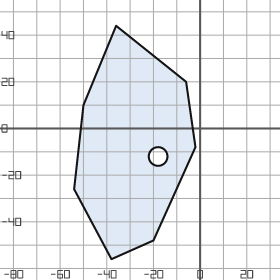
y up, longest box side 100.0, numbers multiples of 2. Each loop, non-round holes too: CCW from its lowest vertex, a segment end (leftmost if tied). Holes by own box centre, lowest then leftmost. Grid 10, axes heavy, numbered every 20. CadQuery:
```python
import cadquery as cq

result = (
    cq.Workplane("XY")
    .moveTo(-38.0, -56.0)
    .lineTo(-20.0, -48.0)
    .lineTo(-2.0, -8.0)
    .lineTo(-6.0, 20.0)
    .lineTo(-36.0, 44.0)
    .lineTo(-50.0, 10.0)
    .lineTo(-54.0, -26.0)
    .close()
    .moveTo(-18.0, -12.0)
    .circle(4.0)
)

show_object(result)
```